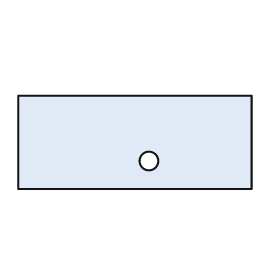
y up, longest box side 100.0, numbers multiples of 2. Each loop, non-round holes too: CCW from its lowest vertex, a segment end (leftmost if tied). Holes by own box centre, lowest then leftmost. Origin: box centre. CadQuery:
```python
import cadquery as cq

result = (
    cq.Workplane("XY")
    .moveTo(-50.0, -20.0)
    .lineTo(50.0, -20.0)
    .lineTo(50.0, 20.0)
    .lineTo(-50.0, 20.0)
    .close()
    .moveTo(6.0, -8.0)
    .circle(4.0)
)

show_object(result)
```